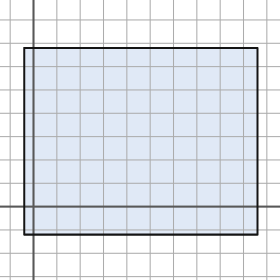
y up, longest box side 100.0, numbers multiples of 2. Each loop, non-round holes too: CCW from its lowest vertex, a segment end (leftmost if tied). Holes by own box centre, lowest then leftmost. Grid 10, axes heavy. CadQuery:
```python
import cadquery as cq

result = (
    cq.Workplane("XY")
    .moveTo(-4.0, -12.0)
    .lineTo(96.0, -12.0)
    .lineTo(96.0, 68.0)
    .lineTo(-4.0, 68.0)
    .close()
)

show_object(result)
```